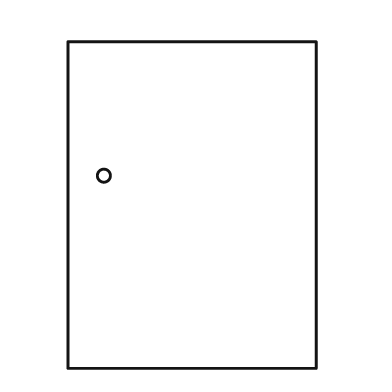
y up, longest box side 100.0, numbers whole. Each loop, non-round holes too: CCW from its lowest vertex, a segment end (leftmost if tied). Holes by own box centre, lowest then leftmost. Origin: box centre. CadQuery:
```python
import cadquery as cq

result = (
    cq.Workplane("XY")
    .moveTo(-38.0, -50.0)
    .lineTo(38.0, -50.0)
    .lineTo(38.0, 50.0)
    .lineTo(-38.0, 50.0)
    .close()
    .moveTo(-27.0, 9.0)
    .circle(2.0)
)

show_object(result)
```